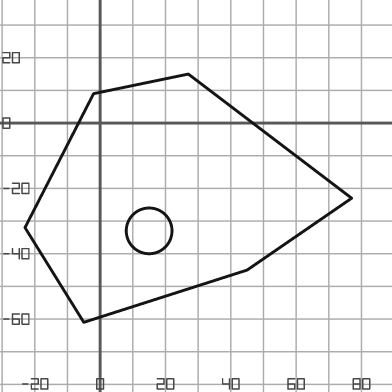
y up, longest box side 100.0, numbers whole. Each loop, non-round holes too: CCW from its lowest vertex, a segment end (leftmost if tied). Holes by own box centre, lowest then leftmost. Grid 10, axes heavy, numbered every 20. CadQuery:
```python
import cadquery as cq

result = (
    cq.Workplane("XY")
    .moveTo(-5.0, -61.0)
    .lineTo(45.0, -45.0)
    .lineTo(77.0, -23.0)
    .lineTo(27.0, 15.0)
    .lineTo(-2.0, 9.0)
    .lineTo(-23.0, -32.0)
    .close()
    .moveTo(15.0, -33.0)
    .circle(7.0)
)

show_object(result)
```